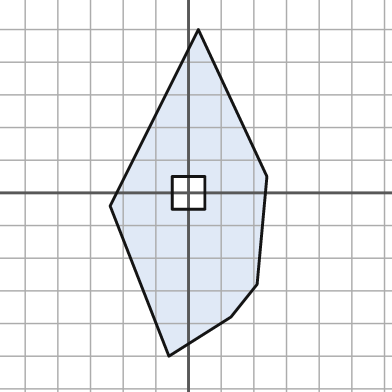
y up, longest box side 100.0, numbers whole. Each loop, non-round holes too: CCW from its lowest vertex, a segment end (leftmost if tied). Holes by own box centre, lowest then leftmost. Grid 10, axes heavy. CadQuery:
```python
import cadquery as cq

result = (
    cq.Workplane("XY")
    .moveTo(-6.0, -50.0)
    .lineTo(13.0, -38.0)
    .lineTo(21.0, -28.0)
    .lineTo(24.0, 5.0)
    .lineTo(3.0, 50.0)
    .lineTo(-24.0, -4.0)
    .close()
    .moveTo(-5.0, -5.0)
    .lineTo(5.0, -5.0)
    .lineTo(5.0, 5.0)
    .lineTo(-5.0, 5.0)
    .close()
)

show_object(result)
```